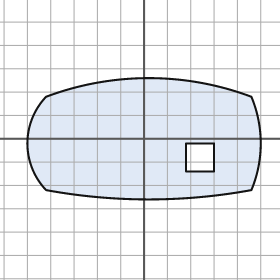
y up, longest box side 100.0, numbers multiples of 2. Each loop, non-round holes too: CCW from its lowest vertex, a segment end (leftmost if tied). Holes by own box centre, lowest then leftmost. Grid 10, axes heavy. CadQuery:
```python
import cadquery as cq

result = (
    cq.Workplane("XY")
    .moveTo(-42.0, -22.0)
    .threePointArc((2.0, -26.0), (46.0, -22.0))
    .threePointArc((50.0, -2.0), (46.0, 18.0))
    .threePointArc((2.0, 26.0), (-42.0, 18.0))
    .threePointArc((-50.0, -2.0), (-42.0, -22.0))
    .close()
    .moveTo(18.0, -14.0)
    .lineTo(30.0, -14.0)
    .lineTo(30.0, -2.0)
    .lineTo(18.0, -2.0)
    .close()
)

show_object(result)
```